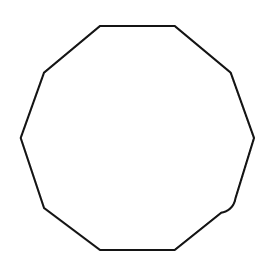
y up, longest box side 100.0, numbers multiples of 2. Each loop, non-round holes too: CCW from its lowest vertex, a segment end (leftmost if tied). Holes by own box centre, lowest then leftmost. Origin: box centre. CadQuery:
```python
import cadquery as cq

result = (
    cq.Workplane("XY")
    .moveTo(-16.0, -48.0)
    .lineTo(16.0, -48.0)
    .lineTo(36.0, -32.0)
    .threePointArc((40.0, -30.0), (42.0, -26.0))
    .lineTo(50.0, 0.0)
    .lineTo(40.0, 28.0)
    .lineTo(16.0, 48.0)
    .lineTo(-16.0, 48.0)
    .lineTo(-40.0, 28.0)
    .lineTo(-50.0, 0.0)
    .lineTo(-40.0, -30.0)
    .close()
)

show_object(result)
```